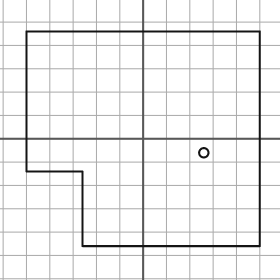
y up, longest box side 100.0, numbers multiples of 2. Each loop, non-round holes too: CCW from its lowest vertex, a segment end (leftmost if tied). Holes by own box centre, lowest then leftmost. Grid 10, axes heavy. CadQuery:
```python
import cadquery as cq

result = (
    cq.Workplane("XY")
    .moveTo(-26.0, -46.0)
    .lineTo(50.0, -46.0)
    .lineTo(50.0, 46.0)
    .lineTo(-50.0, 46.0)
    .lineTo(-50.0, -14.0)
    .lineTo(-26.0, -14.0)
    .close()
    .moveTo(26.0, -6.0)
    .circle(2.0)
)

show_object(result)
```